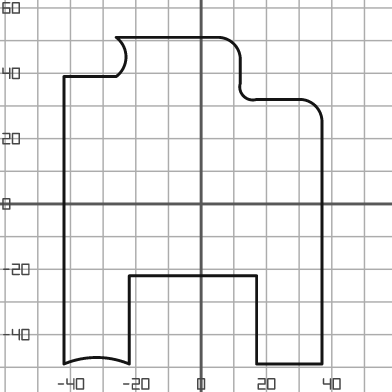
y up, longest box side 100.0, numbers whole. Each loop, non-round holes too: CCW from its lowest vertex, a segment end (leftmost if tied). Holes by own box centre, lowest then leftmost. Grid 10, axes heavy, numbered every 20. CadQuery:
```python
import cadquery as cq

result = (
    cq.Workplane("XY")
    .moveTo(-42.0, -49.0)
    .threePointArc((-32.0, -47.0), (-22.0, -49.0))
    .lineTo(-22.0, -22.0)
    .lineTo(17.0, -22.0)
    .lineTo(17.0, -49.0)
    .lineTo(37.0, -49.0)
    .lineTo(37.0, 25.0)
    .threePointArc((35.0, 30.0), (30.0, 32.0))
    .lineTo(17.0, 32.0)
    .threePointArc((13.0, 33.0), (12.0, 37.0))
    .lineTo(12.0, 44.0)
    .threePointArc((10.0, 49.0), (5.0, 51.0))
    .lineTo(-26.0, 51.0)
    .threePointArc((-23.0, 45.0), (-26.0, 39.0))
    .lineTo(-42.0, 39.0)
    .close()
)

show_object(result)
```